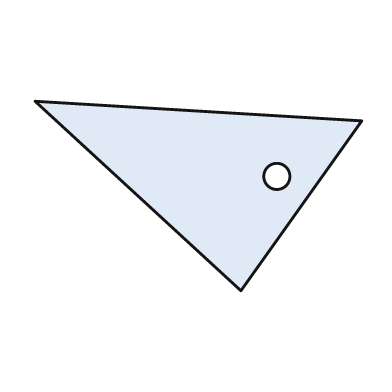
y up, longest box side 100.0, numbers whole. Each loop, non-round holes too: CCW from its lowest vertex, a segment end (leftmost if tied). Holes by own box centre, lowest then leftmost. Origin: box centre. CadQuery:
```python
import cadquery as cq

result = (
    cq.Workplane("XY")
    .moveTo(13.0, -29.0)
    .lineTo(50.0, 23.0)
    .lineTo(-50.0, 29.0)
    .close()
    .moveTo(24.0, 6.0)
    .circle(4.0)
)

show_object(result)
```